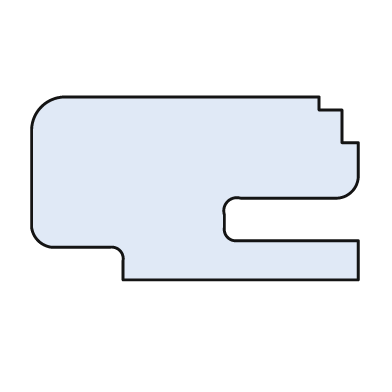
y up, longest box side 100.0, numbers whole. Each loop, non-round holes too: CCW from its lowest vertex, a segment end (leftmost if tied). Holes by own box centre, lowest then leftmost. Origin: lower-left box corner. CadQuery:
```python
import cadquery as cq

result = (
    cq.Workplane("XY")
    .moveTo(28.0, 0.0)
    .lineTo(100.0, 0.0)
    .lineTo(100.0, 12.0)
    .lineTo(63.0, 12.0)
    .threePointArc((60.0, 13.0), (59.0, 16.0))
    .lineTo(59.0, 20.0)
    .threePointArc((60.0, 24.0), (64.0, 25.0))
    .lineTo(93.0, 25.0)
    .threePointArc((98.0, 27.0), (100.0, 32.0))
    .lineTo(100.0, 42.0)
    .lineTo(95.0, 42.0)
    .lineTo(95.0, 52.0)
    .lineTo(88.0, 52.0)
    .lineTo(88.0, 56.0)
    .lineTo(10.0, 56.0)
    .threePointArc((3.0, 53.0), (0.0, 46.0))
    .lineTo(0.0, 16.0)
    .threePointArc((2.0, 12.0), (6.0, 10.0))
    .lineTo(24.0, 10.0)
    .threePointArc((27.0, 9.0), (28.0, 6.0))
    .close()
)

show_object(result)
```